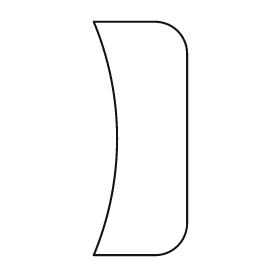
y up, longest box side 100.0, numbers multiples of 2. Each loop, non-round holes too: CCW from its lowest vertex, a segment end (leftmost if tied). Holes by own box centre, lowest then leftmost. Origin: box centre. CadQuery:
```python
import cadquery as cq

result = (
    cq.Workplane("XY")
    .moveTo(-20.0, -50.0)
    .lineTo(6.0, -50.0)
    .threePointArc((16.0, -46.0), (20.0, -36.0))
    .lineTo(20.0, 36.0)
    .threePointArc((16.0, 46.0), (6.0, 50.0))
    .lineTo(-20.0, 50.0)
    .threePointArc((-10.0, 0.0), (-20.0, -50.0))
    .close()
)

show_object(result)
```